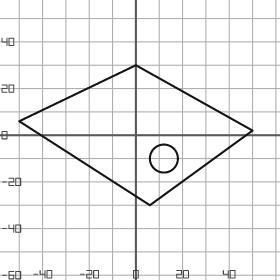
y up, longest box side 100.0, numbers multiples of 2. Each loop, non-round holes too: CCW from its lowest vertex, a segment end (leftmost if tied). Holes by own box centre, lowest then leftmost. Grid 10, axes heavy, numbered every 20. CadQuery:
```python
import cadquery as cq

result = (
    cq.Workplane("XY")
    .moveTo(6.0, -30.0)
    .lineTo(50.0, 2.0)
    .lineTo(0.0, 30.0)
    .lineTo(-50.0, 6.0)
    .close()
    .moveTo(12.0, -10.0)
    .circle(6.0)
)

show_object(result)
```